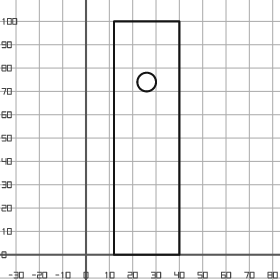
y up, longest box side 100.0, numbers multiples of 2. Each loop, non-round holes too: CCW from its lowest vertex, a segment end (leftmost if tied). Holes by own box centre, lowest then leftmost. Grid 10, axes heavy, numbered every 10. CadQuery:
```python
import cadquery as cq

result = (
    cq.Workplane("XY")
    .moveTo(12.0, 0.0)
    .lineTo(40.0, 0.0)
    .lineTo(40.0, 100.0)
    .lineTo(12.0, 100.0)
    .close()
    .moveTo(26.0, 74.0)
    .circle(4.0)
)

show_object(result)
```